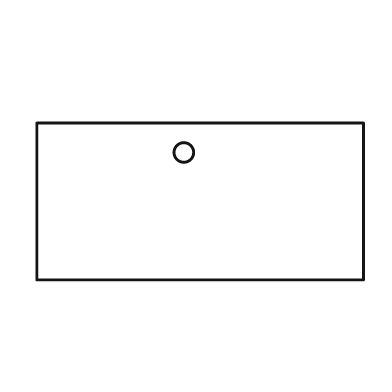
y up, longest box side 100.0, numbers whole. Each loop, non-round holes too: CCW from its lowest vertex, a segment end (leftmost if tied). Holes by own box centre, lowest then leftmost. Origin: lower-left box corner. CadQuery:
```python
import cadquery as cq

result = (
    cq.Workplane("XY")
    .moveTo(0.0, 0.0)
    .lineTo(100.0, 0.0)
    .lineTo(100.0, 48.0)
    .lineTo(0.0, 48.0)
    .close()
    .moveTo(45.0, 39.0)
    .circle(3.0)
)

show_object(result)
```